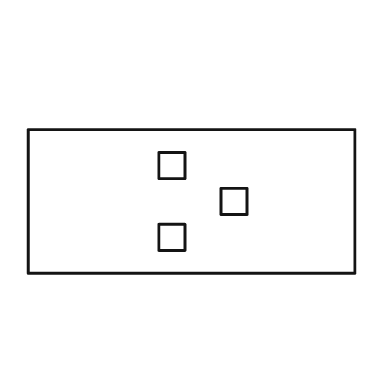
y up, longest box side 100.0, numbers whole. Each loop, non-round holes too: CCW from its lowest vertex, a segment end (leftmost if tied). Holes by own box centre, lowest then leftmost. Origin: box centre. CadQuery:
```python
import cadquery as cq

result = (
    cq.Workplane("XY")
    .moveTo(-50.0, -22.0)
    .lineTo(50.0, -22.0)
    .lineTo(50.0, 22.0)
    .lineTo(-50.0, 22.0)
    .close()
    .moveTo(-10.0, -15.0)
    .lineTo(-2.0, -15.0)
    .lineTo(-2.0, -7.0)
    .lineTo(-10.0, -7.0)
    .close()
    .moveTo(9.0, -4.0)
    .lineTo(17.0, -4.0)
    .lineTo(17.0, 4.0)
    .lineTo(9.0, 4.0)
    .close()
    .moveTo(-10.0, 7.0)
    .lineTo(-2.0, 7.0)
    .lineTo(-2.0, 15.0)
    .lineTo(-10.0, 15.0)
    .close()
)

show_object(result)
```